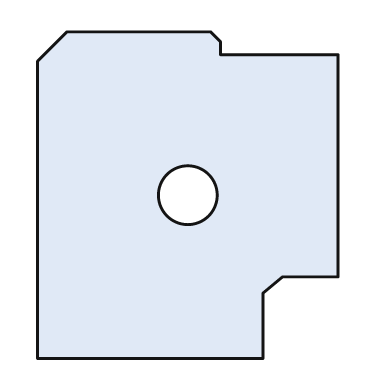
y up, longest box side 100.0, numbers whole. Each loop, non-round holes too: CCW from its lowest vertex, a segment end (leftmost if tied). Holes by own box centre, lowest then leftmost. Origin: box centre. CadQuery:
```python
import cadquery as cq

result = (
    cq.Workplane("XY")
    .moveTo(-46.0, -50.0)
    .lineTo(23.0, -50.0)
    .lineTo(23.0, -30.0)
    .lineTo(29.0, -25.0)
    .lineTo(46.0, -25.0)
    .lineTo(46.0, 43.0)
    .lineTo(10.0, 43.0)
    .lineTo(10.0, 47.0)
    .lineTo(7.0, 50.0)
    .lineTo(-37.0, 50.0)
    .lineTo(-46.0, 41.0)
    .close()
    .moveTo(0.0, 0.0)
    .circle(9.0)
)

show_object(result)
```